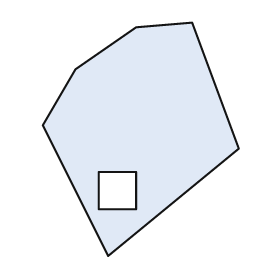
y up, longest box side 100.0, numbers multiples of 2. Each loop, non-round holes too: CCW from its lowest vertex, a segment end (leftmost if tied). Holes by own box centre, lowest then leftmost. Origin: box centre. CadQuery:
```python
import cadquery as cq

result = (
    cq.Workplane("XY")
    .moveTo(-14.0, -50.0)
    .lineTo(42.0, -4.0)
    .lineTo(22.0, 50.0)
    .lineTo(-2.0, 48.0)
    .lineTo(-28.0, 30.0)
    .lineTo(-42.0, 6.0)
    .close()
    .moveTo(-18.0, -30.0)
    .lineTo(-2.0, -30.0)
    .lineTo(-2.0, -14.0)
    .lineTo(-18.0, -14.0)
    .close()
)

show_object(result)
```